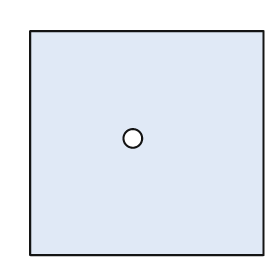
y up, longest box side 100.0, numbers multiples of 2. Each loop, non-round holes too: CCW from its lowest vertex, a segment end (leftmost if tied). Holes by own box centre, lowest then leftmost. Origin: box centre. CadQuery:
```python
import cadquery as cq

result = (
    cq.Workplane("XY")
    .moveTo(-50.0, -48.0)
    .lineTo(50.0, -48.0)
    .lineTo(50.0, 48.0)
    .lineTo(-50.0, 48.0)
    .close()
    .moveTo(-6.0, 2.0)
    .circle(4.0)
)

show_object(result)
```